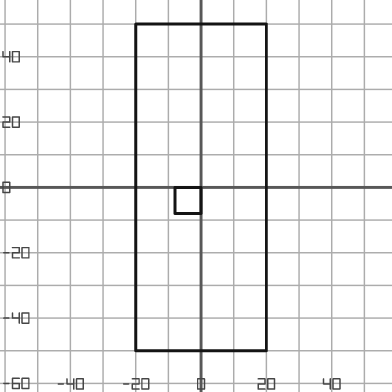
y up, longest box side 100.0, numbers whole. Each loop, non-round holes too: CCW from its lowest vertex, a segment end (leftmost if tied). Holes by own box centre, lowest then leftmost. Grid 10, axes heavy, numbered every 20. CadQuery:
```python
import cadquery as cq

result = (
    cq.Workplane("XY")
    .moveTo(-20.0, -50.0)
    .lineTo(20.0, -50.0)
    .lineTo(20.0, 50.0)
    .lineTo(-20.0, 50.0)
    .close()
    .moveTo(-8.0, -8.0)
    .lineTo(0.0, -8.0)
    .lineTo(0.0, 0.0)
    .lineTo(-8.0, 0.0)
    .close()
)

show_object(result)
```